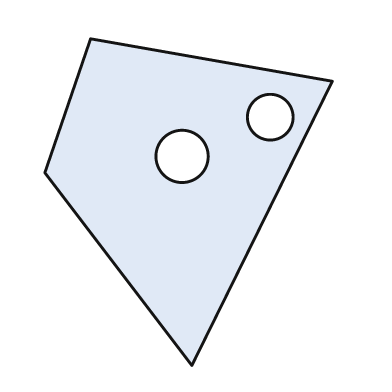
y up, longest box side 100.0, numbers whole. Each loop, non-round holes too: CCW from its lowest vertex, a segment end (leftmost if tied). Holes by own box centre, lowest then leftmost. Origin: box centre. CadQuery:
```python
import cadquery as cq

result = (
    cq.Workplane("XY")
    .moveTo(1.0, -50.0)
    .lineTo(44.0, 37.0)
    .lineTo(-30.0, 50.0)
    .lineTo(-44.0, 9.0)
    .close()
    .moveTo(-2.0, 14.0)
    .circle(8.0)
    .moveTo(25.0, 26.0)
    .circle(7.0)
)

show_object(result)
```